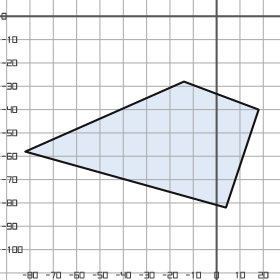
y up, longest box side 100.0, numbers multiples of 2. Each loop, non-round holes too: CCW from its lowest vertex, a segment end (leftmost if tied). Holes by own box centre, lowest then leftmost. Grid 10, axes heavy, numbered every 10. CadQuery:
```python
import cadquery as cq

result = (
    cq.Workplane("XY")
    .moveTo(4.0, -82.0)
    .lineTo(18.0, -40.0)
    .lineTo(-14.0, -28.0)
    .lineTo(-82.0, -58.0)
    .close()
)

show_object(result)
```